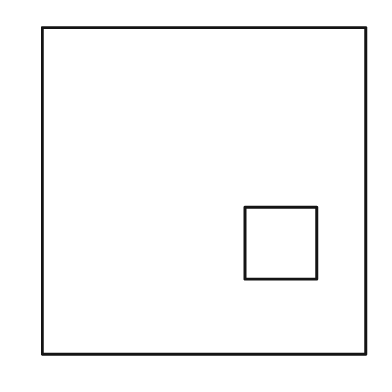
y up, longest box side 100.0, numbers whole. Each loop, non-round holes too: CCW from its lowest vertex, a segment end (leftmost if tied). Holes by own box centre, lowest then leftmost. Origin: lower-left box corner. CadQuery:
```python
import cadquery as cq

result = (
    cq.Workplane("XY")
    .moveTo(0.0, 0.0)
    .lineTo(99.0, 0.0)
    .lineTo(99.0, 100.0)
    .lineTo(0.0, 100.0)
    .close()
    .moveTo(62.0, 23.0)
    .lineTo(84.0, 23.0)
    .lineTo(84.0, 45.0)
    .lineTo(62.0, 45.0)
    .close()
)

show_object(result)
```